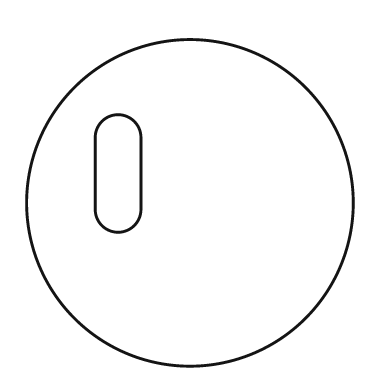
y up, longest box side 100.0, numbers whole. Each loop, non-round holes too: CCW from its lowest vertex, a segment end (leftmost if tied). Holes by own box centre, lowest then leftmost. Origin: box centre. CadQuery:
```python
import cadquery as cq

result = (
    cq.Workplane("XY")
    .moveTo(0.0, 0.0)
    .circle(50.0)
    .moveTo(-29.0, -2.0)
    .threePointArc((-22.0, -9.0), (-15.0, -2.0))
    .lineTo(-15.0, 20.0)
    .threePointArc((-22.0, 27.0), (-29.0, 20.0))
    .close()
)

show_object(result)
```